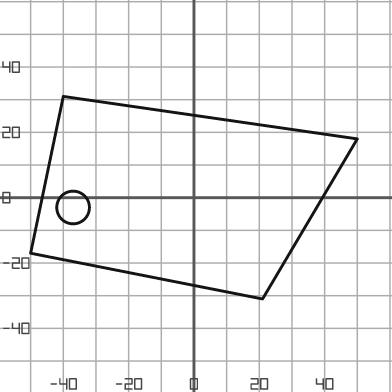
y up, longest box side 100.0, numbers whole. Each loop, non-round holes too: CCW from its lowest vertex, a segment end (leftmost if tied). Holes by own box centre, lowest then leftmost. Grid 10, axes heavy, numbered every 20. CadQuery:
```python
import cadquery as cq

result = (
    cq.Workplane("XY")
    .moveTo(21.0, -31.0)
    .lineTo(50.0, 18.0)
    .lineTo(-40.0, 31.0)
    .lineTo(-50.0, -17.0)
    .close()
    .moveTo(-37.0, -3.0)
    .circle(5.0)
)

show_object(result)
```